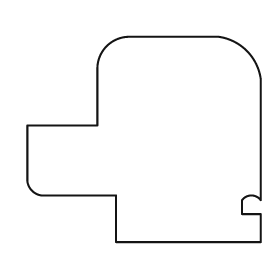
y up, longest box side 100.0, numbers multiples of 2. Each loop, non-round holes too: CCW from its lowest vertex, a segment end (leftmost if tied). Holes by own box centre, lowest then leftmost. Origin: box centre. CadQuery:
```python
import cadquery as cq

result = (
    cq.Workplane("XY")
    .moveTo(-12.0, -44.0)
    .lineTo(50.0, -44.0)
    .lineTo(50.0, -32.0)
    .lineTo(42.0, -32.0)
    .lineTo(42.0, -26.0)
    .threePointArc((46.0, -24.0), (50.0, -26.0))
    .lineTo(50.0, 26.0)
    .threePointArc((44.0, 38.0), (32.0, 44.0))
    .lineTo(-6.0, 44.0)
    .threePointArc((-16.0, 40.0), (-20.0, 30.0))
    .lineTo(-20.0, 6.0)
    .lineTo(-50.0, 6.0)
    .lineTo(-50.0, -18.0)
    .threePointArc((-48.0, -22.0), (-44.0, -24.0))
    .lineTo(-12.0, -24.0)
    .close()
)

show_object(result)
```